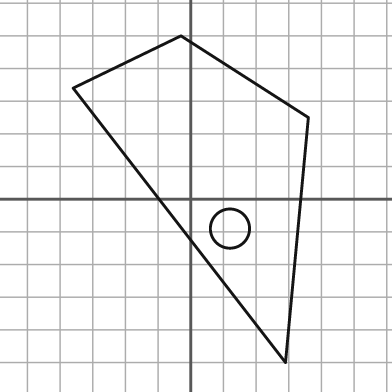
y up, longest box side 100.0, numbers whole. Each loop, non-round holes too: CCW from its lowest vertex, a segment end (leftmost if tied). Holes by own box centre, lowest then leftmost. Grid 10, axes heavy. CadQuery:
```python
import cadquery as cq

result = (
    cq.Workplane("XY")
    .moveTo(29.0, -50.0)
    .lineTo(36.0, 25.0)
    .lineTo(-3.0, 50.0)
    .lineTo(-36.0, 34.0)
    .close()
    .moveTo(12.0, -9.0)
    .circle(6.0)
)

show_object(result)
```